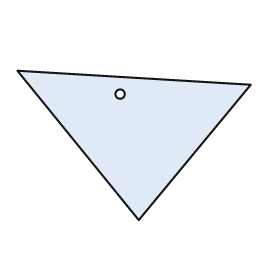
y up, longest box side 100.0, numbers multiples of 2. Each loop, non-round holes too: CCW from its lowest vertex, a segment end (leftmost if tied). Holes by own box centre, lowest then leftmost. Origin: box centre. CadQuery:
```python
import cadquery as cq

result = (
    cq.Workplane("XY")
    .moveTo(2.0, -32.0)
    .lineTo(50.0, 26.0)
    .lineTo(-50.0, 32.0)
    .close()
    .moveTo(-6.0, 22.0)
    .circle(2.0)
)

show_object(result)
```